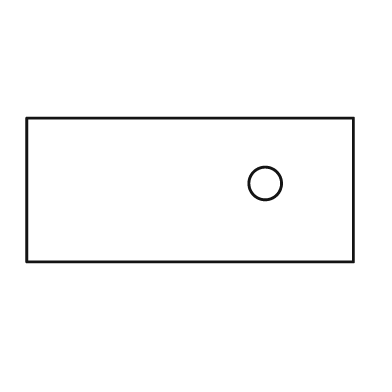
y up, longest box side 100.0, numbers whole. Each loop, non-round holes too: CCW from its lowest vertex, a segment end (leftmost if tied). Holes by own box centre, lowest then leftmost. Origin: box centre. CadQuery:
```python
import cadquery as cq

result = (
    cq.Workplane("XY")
    .moveTo(-50.0, -22.0)
    .lineTo(50.0, -22.0)
    .lineTo(50.0, 22.0)
    .lineTo(-50.0, 22.0)
    .close()
    .moveTo(23.0, 2.0)
    .circle(5.0)
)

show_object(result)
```